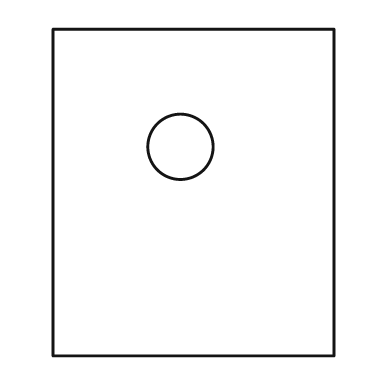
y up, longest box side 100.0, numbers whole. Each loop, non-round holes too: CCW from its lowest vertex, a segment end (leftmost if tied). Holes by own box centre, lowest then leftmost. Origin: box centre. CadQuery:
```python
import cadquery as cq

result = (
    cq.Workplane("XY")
    .moveTo(-43.0, -50.0)
    .lineTo(43.0, -50.0)
    .lineTo(43.0, 50.0)
    .lineTo(-43.0, 50.0)
    .close()
    .moveTo(-4.0, 14.0)
    .circle(10.0)
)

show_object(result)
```